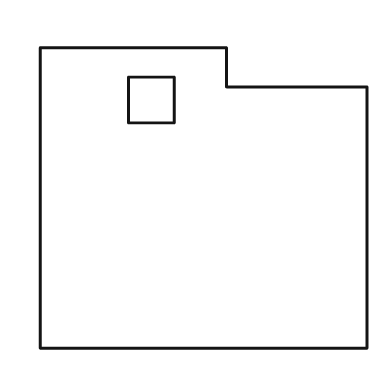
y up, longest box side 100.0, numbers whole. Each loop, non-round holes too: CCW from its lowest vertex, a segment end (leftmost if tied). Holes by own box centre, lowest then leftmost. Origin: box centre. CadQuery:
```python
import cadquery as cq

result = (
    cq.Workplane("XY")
    .moveTo(-50.0, -46.0)
    .lineTo(50.0, -46.0)
    .lineTo(50.0, 34.0)
    .lineTo(7.0, 34.0)
    .lineTo(7.0, 46.0)
    .lineTo(-50.0, 46.0)
    .close()
    .moveTo(-23.0, 23.0)
    .lineTo(-9.0, 23.0)
    .lineTo(-9.0, 37.0)
    .lineTo(-23.0, 37.0)
    .close()
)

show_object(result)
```